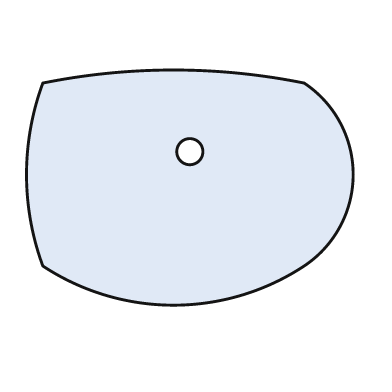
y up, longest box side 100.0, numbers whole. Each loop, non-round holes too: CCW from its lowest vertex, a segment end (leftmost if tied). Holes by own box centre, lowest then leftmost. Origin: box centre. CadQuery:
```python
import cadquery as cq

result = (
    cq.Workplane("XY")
    .moveTo(-45.0, -24.0)
    .threePointArc((-5.0, -36.0), (35.0, -24.0))
    .threePointArc((50.0, 4.0), (35.0, 32.0))
    .threePointArc((-5.0, 36.0), (-45.0, 32.0))
    .threePointArc((-50.0, 4.0), (-45.0, -24.0))
    .close()
    .moveTo(0.0, 11.0)
    .circle(4.0)
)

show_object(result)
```